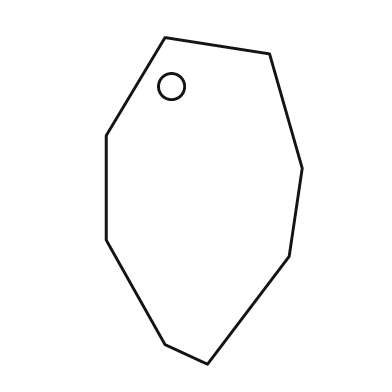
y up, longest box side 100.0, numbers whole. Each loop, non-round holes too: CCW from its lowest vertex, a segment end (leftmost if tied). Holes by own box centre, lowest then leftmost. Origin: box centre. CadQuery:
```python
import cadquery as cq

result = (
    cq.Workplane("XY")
    .moveTo(1.0, -50.0)
    .lineTo(26.0, -17.0)
    .lineTo(30.0, 10.0)
    .lineTo(20.0, 45.0)
    .lineTo(-12.0, 50.0)
    .lineTo(-30.0, 20.0)
    .lineTo(-30.0, -12.0)
    .lineTo(-12.0, -44.0)
    .close()
    .moveTo(-10.0, 35.0)
    .circle(4.0)
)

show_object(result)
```